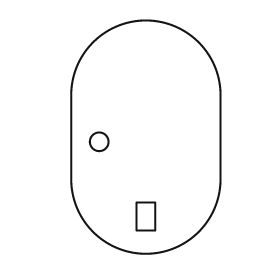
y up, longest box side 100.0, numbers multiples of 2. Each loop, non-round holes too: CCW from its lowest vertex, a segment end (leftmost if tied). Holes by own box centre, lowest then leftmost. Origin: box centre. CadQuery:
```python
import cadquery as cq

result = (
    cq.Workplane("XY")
    .moveTo(-32.0, -18.0)
    .threePointArc((0.0, -50.0), (32.0, -18.0))
    .lineTo(32.0, 18.0)
    .threePointArc((0.0, 50.0), (-32.0, 18.0))
    .close()
    .moveTo(-4.0, -40.0)
    .lineTo(4.0, -40.0)
    .lineTo(4.0, -28.0)
    .lineTo(-4.0, -28.0)
    .close()
    .moveTo(-20.0, -2.0)
    .circle(4.0)
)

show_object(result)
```